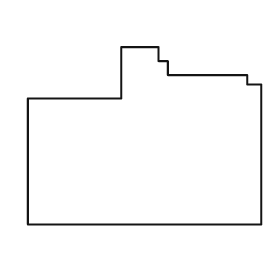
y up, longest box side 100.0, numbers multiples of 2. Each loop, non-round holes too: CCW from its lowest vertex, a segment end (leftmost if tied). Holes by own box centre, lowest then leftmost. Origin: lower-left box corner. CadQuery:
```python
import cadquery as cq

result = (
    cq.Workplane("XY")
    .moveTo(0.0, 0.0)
    .lineTo(100.0, 0.0)
    .lineTo(100.0, 60.0)
    .lineTo(94.0, 60.0)
    .lineTo(94.0, 64.0)
    .lineTo(60.0, 64.0)
    .lineTo(60.0, 70.0)
    .lineTo(56.0, 70.0)
    .lineTo(56.0, 76.0)
    .lineTo(40.0, 76.0)
    .lineTo(40.0, 54.0)
    .lineTo(0.0, 54.0)
    .close()
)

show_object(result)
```